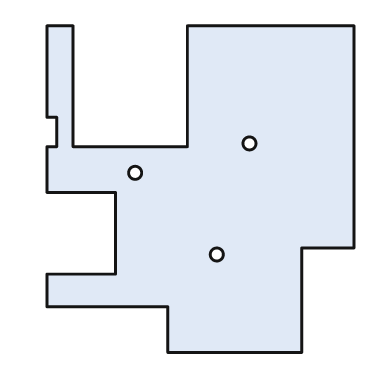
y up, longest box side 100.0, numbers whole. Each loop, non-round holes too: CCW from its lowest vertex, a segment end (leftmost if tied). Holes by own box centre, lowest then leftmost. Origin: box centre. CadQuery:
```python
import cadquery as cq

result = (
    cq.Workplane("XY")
    .moveTo(-10.0, -50.0)
    .lineTo(31.0, -50.0)
    .lineTo(31.0, -18.0)
    .lineTo(47.0, -18.0)
    .lineTo(47.0, 50.0)
    .lineTo(-4.0, 50.0)
    .lineTo(-4.0, 13.0)
    .lineTo(-39.0, 13.0)
    .lineTo(-39.0, 50.0)
    .lineTo(-47.0, 50.0)
    .lineTo(-47.0, 22.0)
    .lineTo(-44.0, 22.0)
    .lineTo(-44.0, 13.0)
    .lineTo(-47.0, 13.0)
    .lineTo(-47.0, -1.0)
    .lineTo(-26.0, -1.0)
    .lineTo(-26.0, -26.0)
    .lineTo(-47.0, -26.0)
    .lineTo(-47.0, -36.0)
    .lineTo(-10.0, -36.0)
    .close()
    .moveTo(5.0, -20.0)
    .circle(2.0)
    .moveTo(-20.0, 5.0)
    .circle(2.0)
    .moveTo(15.0, 14.0)
    .circle(2.0)
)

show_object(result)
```